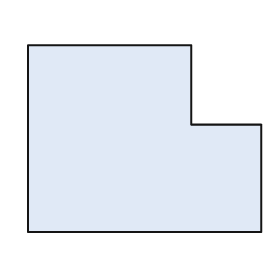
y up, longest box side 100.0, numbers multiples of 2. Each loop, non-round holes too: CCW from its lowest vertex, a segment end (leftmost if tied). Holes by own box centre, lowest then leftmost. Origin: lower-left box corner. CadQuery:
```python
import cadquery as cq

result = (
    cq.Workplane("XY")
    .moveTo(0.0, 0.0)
    .lineTo(100.0, 0.0)
    .lineTo(100.0, 46.0)
    .lineTo(70.0, 46.0)
    .lineTo(70.0, 80.0)
    .lineTo(0.0, 80.0)
    .close()
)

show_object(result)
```